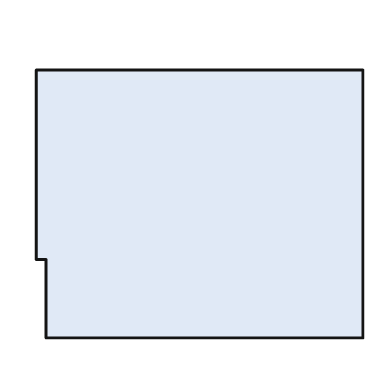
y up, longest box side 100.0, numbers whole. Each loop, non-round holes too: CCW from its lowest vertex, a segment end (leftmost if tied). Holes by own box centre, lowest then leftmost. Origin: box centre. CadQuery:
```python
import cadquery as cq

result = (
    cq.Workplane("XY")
    .moveTo(-47.0, -41.0)
    .lineTo(50.0, -41.0)
    .lineTo(50.0, 41.0)
    .lineTo(-50.0, 41.0)
    .lineTo(-50.0, -17.0)
    .lineTo(-47.0, -17.0)
    .close()
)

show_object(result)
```